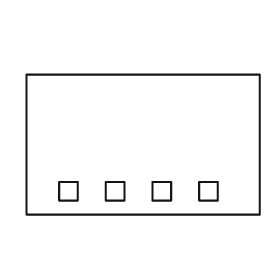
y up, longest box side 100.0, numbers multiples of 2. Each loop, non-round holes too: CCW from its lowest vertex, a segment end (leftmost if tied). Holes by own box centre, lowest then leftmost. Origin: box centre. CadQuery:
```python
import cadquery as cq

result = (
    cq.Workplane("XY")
    .moveTo(-50.0, -30.0)
    .lineTo(50.0, -30.0)
    .lineTo(50.0, 30.0)
    .lineTo(-50.0, 30.0)
    .close()
    .moveTo(-36.0, -24.0)
    .lineTo(-28.0, -24.0)
    .lineTo(-28.0, -16.0)
    .lineTo(-36.0, -16.0)
    .close()
    .moveTo(-16.0, -24.0)
    .lineTo(-8.0, -24.0)
    .lineTo(-8.0, -16.0)
    .lineTo(-16.0, -16.0)
    .close()
    .moveTo(4.0, -24.0)
    .lineTo(12.0, -24.0)
    .lineTo(12.0, -16.0)
    .lineTo(4.0, -16.0)
    .close()
    .moveTo(24.0, -24.0)
    .lineTo(32.0, -24.0)
    .lineTo(32.0, -16.0)
    .lineTo(24.0, -16.0)
    .close()
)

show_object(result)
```